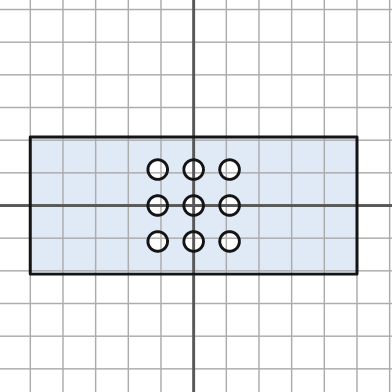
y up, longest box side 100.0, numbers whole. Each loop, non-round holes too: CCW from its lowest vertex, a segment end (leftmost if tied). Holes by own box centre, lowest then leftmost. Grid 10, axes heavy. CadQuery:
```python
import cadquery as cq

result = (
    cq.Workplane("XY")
    .moveTo(-50.0, -21.0)
    .lineTo(50.0, -21.0)
    .lineTo(50.0, 21.0)
    .lineTo(-50.0, 21.0)
    .close()
    .moveTo(-11.0, -11.0)
    .circle(3.0)
    .moveTo(0.0, -11.0)
    .circle(3.0)
    .moveTo(11.0, -11.0)
    .circle(3.0)
    .moveTo(-11.0, 0.0)
    .circle(3.0)
    .moveTo(0.0, 0.0)
    .circle(3.0)
    .moveTo(11.0, 0.0)
    .circle(3.0)
    .moveTo(-11.0, 11.0)
    .circle(3.0)
    .moveTo(0.0, 11.0)
    .circle(3.0)
    .moveTo(11.0, 11.0)
    .circle(3.0)
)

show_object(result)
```